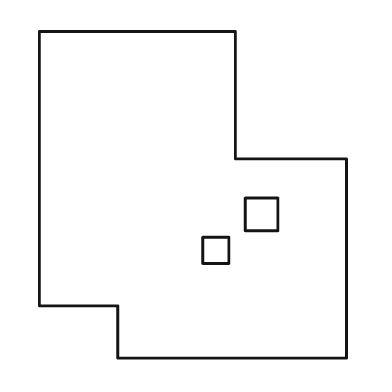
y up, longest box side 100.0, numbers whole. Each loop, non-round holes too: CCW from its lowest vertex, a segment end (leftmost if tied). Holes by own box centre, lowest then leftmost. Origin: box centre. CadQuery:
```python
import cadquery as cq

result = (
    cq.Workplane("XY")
    .moveTo(-23.0, -50.0)
    .lineTo(47.0, -50.0)
    .lineTo(47.0, 11.0)
    .lineTo(13.0, 11.0)
    .lineTo(13.0, 50.0)
    .lineTo(-47.0, 50.0)
    .lineTo(-47.0, -34.0)
    .lineTo(-23.0, -34.0)
    .close()
    .moveTo(3.0, -21.0)
    .lineTo(11.0, -21.0)
    .lineTo(11.0, -13.0)
    .lineTo(3.0, -13.0)
    .close()
    .moveTo(16.0, -11.0)
    .lineTo(26.0, -11.0)
    .lineTo(26.0, -1.0)
    .lineTo(16.0, -1.0)
    .close()
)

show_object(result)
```